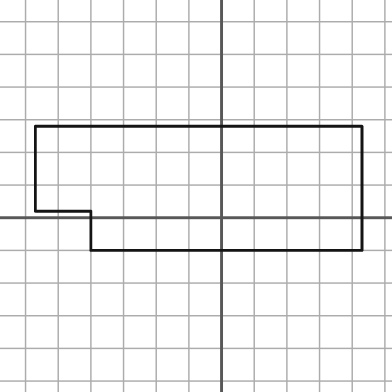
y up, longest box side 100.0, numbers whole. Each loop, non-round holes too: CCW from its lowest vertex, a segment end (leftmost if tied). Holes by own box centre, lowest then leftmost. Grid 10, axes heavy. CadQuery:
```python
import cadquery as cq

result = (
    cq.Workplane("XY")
    .moveTo(-40.0, -10.0)
    .lineTo(43.0, -10.0)
    .lineTo(43.0, 28.0)
    .lineTo(-57.0, 28.0)
    .lineTo(-57.0, 2.0)
    .lineTo(-40.0, 2.0)
    .close()
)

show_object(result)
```